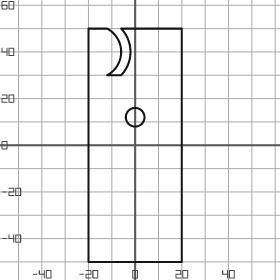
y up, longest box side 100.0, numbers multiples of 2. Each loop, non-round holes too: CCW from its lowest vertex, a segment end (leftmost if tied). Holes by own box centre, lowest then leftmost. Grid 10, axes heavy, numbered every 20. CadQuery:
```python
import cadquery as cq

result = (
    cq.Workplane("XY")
    .moveTo(-20.0, -50.0)
    .lineTo(20.0, -50.0)
    .lineTo(20.0, 50.0)
    .lineTo(-6.0, 50.0)
    .threePointArc((-2.0, 40.0), (-6.0, 30.0))
    .lineTo(-12.0, 30.0)
    .threePointArc((-6.0, 40.0), (-12.0, 50.0))
    .lineTo(-20.0, 50.0)
    .close()
    .moveTo(0.0, 12.0)
    .circle(4.0)
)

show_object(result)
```